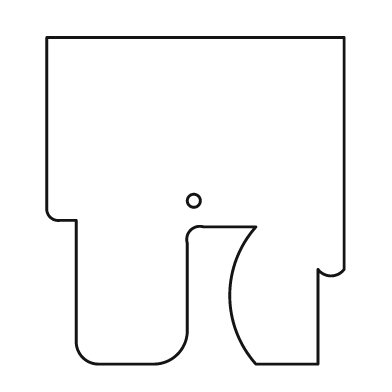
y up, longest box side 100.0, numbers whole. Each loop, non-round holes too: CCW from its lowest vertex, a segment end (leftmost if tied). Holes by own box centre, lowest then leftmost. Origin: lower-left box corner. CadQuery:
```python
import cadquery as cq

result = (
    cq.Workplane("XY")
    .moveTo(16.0, 0.0)
    .lineTo(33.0, 0.0)
    .threePointArc((40.0, 3.0), (43.0, 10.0))
    .lineTo(43.0, 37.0)
    .threePointArc((44.0, 41.0), (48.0, 42.0))
    .lineTo(64.0, 42.0)
    .threePointArc((56.0, 21.0), (64.0, 0.0))
    .lineTo(83.0, 0.0)
    .lineTo(83.0, 29.0)
    .threePointArc((87.0, 27.0), (91.0, 29.0))
    .lineTo(91.0, 100.0)
    .lineTo(0.0, 100.0)
    .lineTo(0.0, 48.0)
    .threePointArc((1.0, 45.0), (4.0, 44.0))
    .lineTo(9.0, 44.0)
    .lineTo(9.0, 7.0)
    .threePointArc((11.0, 2.0), (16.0, 0.0))
    .close()
    .moveTo(45.0, 50.0)
    .circle(2.0)
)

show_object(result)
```